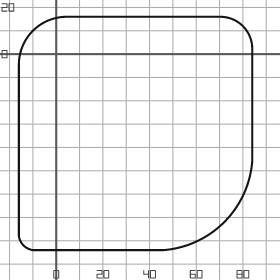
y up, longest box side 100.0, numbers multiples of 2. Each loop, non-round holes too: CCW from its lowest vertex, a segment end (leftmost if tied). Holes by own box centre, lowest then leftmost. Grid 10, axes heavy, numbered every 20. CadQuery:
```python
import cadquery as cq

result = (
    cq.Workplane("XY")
    .moveTo(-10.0, -84.0)
    .lineTo(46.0, -84.0)
    .threePointArc((72.0, -72.0), (84.0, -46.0))
    .lineTo(84.0, 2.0)
    .threePointArc((80.0, 12.0), (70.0, 16.0))
    .lineTo(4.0, 16.0)
    .threePointArc((-10.0, 10.0), (-16.0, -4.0))
    .lineTo(-16.0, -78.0)
    .threePointArc((-14.0, -82.0), (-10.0, -84.0))
    .close()
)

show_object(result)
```